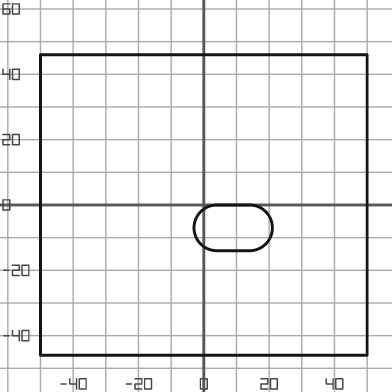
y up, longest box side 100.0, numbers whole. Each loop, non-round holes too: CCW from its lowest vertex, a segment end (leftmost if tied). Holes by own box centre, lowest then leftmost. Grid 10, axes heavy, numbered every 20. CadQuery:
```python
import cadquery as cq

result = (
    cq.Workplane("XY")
    .moveTo(-50.0, -46.0)
    .lineTo(50.0, -46.0)
    .lineTo(50.0, 46.0)
    .lineTo(-50.0, 46.0)
    .close()
    .moveTo(4.0, -14.0)
    .lineTo(14.0, -14.0)
    .threePointArc((21.0, -7.0), (14.0, 0.0))
    .lineTo(4.0, 0.0)
    .threePointArc((-3.0, -7.0), (4.0, -14.0))
    .close()
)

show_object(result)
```